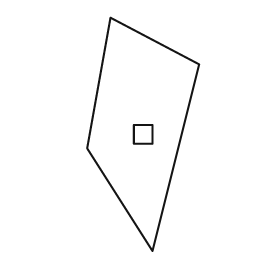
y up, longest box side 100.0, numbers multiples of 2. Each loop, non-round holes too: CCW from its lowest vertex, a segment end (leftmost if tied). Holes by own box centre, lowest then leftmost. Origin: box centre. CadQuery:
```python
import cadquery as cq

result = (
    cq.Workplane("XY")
    .moveTo(4.0, -50.0)
    .lineTo(24.0, 30.0)
    .lineTo(-14.0, 50.0)
    .lineTo(-24.0, -6.0)
    .close()
    .moveTo(-4.0, -4.0)
    .lineTo(4.0, -4.0)
    .lineTo(4.0, 4.0)
    .lineTo(-4.0, 4.0)
    .close()
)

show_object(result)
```